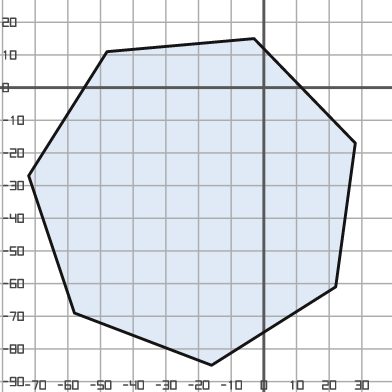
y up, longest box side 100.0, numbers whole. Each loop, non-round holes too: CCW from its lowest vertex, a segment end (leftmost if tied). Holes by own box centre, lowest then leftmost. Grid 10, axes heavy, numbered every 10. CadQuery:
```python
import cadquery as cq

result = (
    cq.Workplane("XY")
    .moveTo(-16.0, -85.0)
    .lineTo(22.0, -61.0)
    .lineTo(28.0, -17.0)
    .lineTo(-3.0, 15.0)
    .lineTo(-48.0, 11.0)
    .lineTo(-72.0, -27.0)
    .lineTo(-58.0, -69.0)
    .close()
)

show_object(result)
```